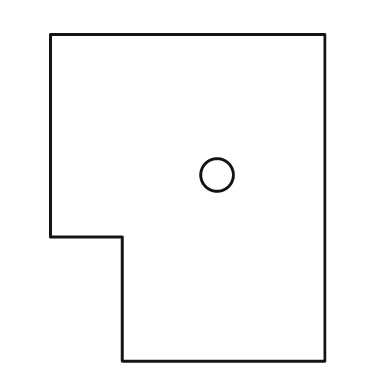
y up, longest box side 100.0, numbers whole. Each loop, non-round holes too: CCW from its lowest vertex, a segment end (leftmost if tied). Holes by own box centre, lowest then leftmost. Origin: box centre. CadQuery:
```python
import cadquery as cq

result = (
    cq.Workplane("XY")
    .moveTo(-20.0, -50.0)
    .lineTo(42.0, -50.0)
    .lineTo(42.0, 50.0)
    .lineTo(-42.0, 50.0)
    .lineTo(-42.0, -12.0)
    .lineTo(-20.0, -12.0)
    .close()
    .moveTo(9.0, 7.0)
    .circle(5.0)
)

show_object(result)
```